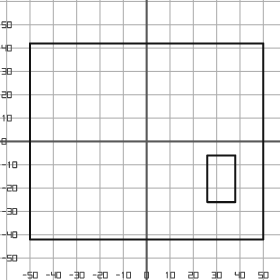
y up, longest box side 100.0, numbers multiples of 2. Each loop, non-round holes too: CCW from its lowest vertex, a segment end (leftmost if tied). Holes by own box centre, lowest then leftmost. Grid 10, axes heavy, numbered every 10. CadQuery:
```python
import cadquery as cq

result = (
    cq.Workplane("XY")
    .moveTo(-50.0, -42.0)
    .lineTo(50.0, -42.0)
    .lineTo(50.0, 42.0)
    .lineTo(-50.0, 42.0)
    .close()
    .moveTo(26.0, -26.0)
    .lineTo(38.0, -26.0)
    .lineTo(38.0, -6.0)
    .lineTo(26.0, -6.0)
    .close()
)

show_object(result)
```